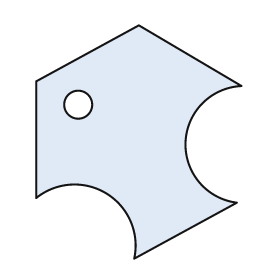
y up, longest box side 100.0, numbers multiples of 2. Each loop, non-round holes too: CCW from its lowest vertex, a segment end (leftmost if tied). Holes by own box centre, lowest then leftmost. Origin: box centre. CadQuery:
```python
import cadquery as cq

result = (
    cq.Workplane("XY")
    .moveTo(-2.0, -50.0)
    .lineTo(42.0, -26.0)
    .threePointArc((20.0, 0.0), (44.0, 24.0))
    .lineTo(0.0, 50.0)
    .lineTo(-44.0, 26.0)
    .lineTo(-44.0, -24.0)
    .threePointArc((-14.0, -22.0), (-2.0, -50.0))
    .close()
    .moveTo(-26.0, 16.0)
    .circle(6.0)
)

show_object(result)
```